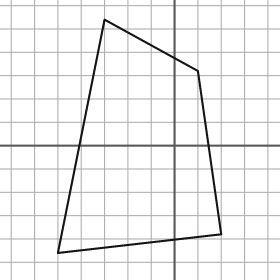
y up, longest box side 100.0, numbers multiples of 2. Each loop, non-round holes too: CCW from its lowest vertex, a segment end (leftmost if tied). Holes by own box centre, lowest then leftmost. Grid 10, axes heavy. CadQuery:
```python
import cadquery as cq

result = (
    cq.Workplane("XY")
    .moveTo(-50.0, -46.0)
    .lineTo(20.0, -38.0)
    .lineTo(10.0, 32.0)
    .lineTo(-30.0, 54.0)
    .close()
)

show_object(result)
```